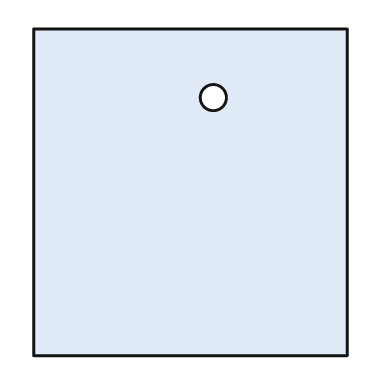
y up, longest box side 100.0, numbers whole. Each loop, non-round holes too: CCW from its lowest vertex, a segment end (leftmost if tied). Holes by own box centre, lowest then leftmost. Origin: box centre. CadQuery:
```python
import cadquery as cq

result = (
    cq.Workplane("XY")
    .moveTo(-48.0, -50.0)
    .lineTo(48.0, -50.0)
    .lineTo(48.0, 50.0)
    .lineTo(-48.0, 50.0)
    .close()
    .moveTo(7.0, 29.0)
    .circle(4.0)
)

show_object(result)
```